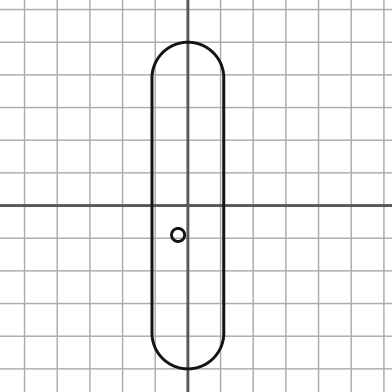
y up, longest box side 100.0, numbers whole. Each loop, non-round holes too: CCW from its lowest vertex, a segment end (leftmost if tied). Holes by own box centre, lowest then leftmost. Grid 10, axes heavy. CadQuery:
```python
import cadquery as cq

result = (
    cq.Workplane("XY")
    .moveTo(-11.0, -39.0)
    .threePointArc((0.0, -50.0), (11.0, -39.0))
    .lineTo(11.0, 39.0)
    .threePointArc((0.0, 50.0), (-11.0, 39.0))
    .close()
    .moveTo(-3.0, -9.0)
    .circle(2.0)
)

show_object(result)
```